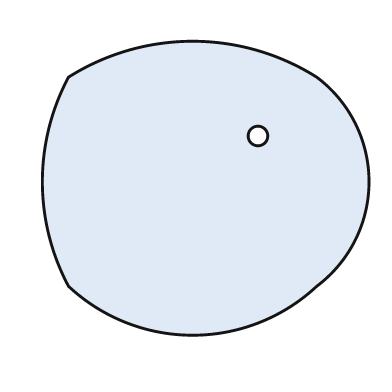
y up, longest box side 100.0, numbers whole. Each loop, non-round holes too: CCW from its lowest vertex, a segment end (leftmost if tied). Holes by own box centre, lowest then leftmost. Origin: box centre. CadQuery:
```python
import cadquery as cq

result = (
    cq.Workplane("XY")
    .moveTo(-42.0, -30.0)
    .threePointArc((-4.0, -45.0), (34.0, -30.0))
    .threePointArc((50.0, 2.0), (34.0, 34.0))
    .threePointArc((-4.0, 45.0), (-42.0, 34.0))
    .threePointArc((-50.0, 2.0), (-42.0, -30.0))
    .close()
    .moveTo(16.0, 16.0)
    .circle(3.0)
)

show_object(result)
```